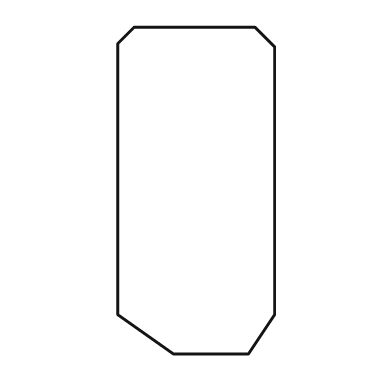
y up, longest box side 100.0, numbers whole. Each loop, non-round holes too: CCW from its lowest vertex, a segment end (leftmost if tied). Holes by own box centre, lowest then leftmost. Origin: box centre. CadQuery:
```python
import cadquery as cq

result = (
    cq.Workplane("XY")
    .moveTo(-7.0, -50.0)
    .lineTo(16.0, -50.0)
    .lineTo(24.0, -38.0)
    .lineTo(24.0, 44.0)
    .lineTo(18.0, 50.0)
    .lineTo(-19.0, 50.0)
    .lineTo(-24.0, 45.0)
    .lineTo(-24.0, -38.0)
    .close()
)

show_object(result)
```